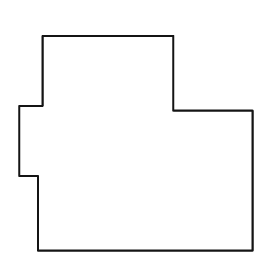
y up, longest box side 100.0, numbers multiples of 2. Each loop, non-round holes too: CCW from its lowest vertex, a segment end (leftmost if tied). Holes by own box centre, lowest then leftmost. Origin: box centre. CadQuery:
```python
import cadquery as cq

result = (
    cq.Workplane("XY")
    .moveTo(-42.0, -46.0)
    .lineTo(50.0, -46.0)
    .lineTo(50.0, 14.0)
    .lineTo(16.0, 14.0)
    .lineTo(16.0, 46.0)
    .lineTo(-40.0, 46.0)
    .lineTo(-40.0, 16.0)
    .lineTo(-50.0, 16.0)
    .lineTo(-50.0, -14.0)
    .lineTo(-42.0, -14.0)
    .close()
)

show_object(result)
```